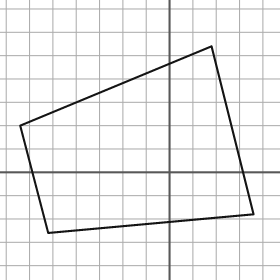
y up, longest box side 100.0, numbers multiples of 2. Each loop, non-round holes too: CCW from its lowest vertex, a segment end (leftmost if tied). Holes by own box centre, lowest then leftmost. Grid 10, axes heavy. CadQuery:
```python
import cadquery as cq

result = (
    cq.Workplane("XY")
    .moveTo(-52.0, -26.0)
    .lineTo(36.0, -18.0)
    .lineTo(18.0, 54.0)
    .lineTo(-64.0, 20.0)
    .close()
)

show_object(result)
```